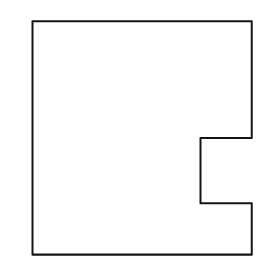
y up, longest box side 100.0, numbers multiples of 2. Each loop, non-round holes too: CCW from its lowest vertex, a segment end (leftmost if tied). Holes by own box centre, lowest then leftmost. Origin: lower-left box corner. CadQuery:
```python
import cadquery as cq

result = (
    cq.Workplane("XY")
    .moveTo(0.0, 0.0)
    .lineTo(94.0, 0.0)
    .lineTo(94.0, 22.0)
    .lineTo(72.0, 22.0)
    .lineTo(72.0, 50.0)
    .lineTo(94.0, 50.0)
    .lineTo(94.0, 100.0)
    .lineTo(0.0, 100.0)
    .close()
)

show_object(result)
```